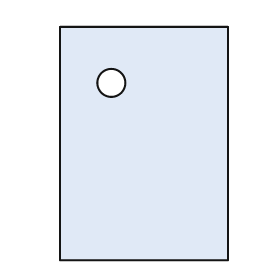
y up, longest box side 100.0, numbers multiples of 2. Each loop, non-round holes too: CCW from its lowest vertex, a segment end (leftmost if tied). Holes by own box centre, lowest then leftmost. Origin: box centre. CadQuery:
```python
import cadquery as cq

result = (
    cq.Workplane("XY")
    .moveTo(-36.0, -50.0)
    .lineTo(36.0, -50.0)
    .lineTo(36.0, 50.0)
    .lineTo(-36.0, 50.0)
    .close()
    .moveTo(-14.0, 26.0)
    .circle(6.0)
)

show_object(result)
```